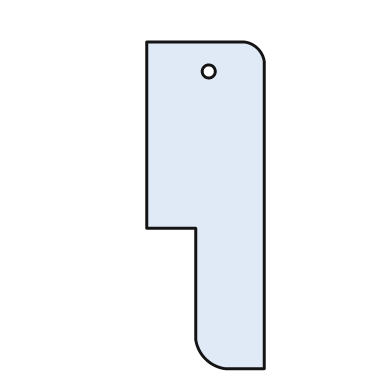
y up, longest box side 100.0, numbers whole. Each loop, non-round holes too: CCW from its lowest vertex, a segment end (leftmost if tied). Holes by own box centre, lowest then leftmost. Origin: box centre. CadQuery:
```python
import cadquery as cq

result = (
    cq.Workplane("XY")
    .moveTo(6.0, -50.0)
    .lineTo(18.0, -50.0)
    .lineTo(18.0, 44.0)
    .threePointArc((16.0, 48.0), (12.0, 50.0))
    .lineTo(-18.0, 50.0)
    .lineTo(-18.0, -7.0)
    .lineTo(-3.0, -7.0)
    .lineTo(-3.0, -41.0)
    .threePointArc((0.0, -47.0), (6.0, -50.0))
    .close()
    .moveTo(1.0, 41.0)
    .circle(2.0)
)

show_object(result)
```